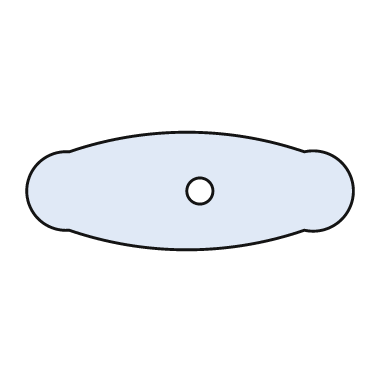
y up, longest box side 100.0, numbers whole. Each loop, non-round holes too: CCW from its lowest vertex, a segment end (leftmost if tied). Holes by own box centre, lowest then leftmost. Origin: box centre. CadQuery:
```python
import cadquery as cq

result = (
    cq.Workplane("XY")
    .moveTo(-37.0, -12.0)
    .threePointArc((-1.0, -18.0), (35.0, -12.0))
    .threePointArc((50.0, 0.0), (35.0, 12.0))
    .threePointArc((-1.0, 18.0), (-37.0, 12.0))
    .threePointArc((-50.0, 0.0), (-37.0, -12.0))
    .close()
    .moveTo(3.0, 0.0)
    .circle(4.0)
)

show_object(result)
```